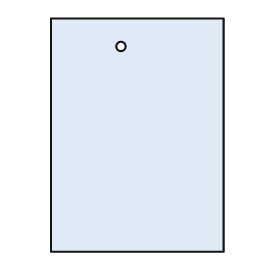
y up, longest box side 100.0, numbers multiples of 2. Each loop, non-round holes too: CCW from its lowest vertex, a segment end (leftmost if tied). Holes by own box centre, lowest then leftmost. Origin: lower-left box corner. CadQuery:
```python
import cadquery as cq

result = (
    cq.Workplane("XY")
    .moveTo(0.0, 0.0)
    .lineTo(74.0, 0.0)
    .lineTo(74.0, 100.0)
    .lineTo(0.0, 100.0)
    .close()
    .moveTo(30.0, 88.0)
    .circle(2.0)
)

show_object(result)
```